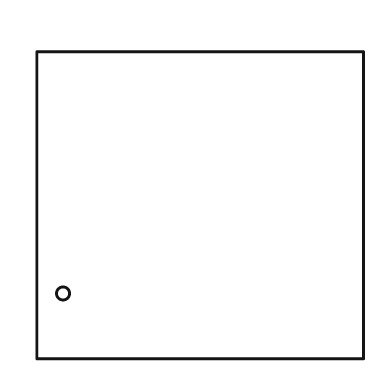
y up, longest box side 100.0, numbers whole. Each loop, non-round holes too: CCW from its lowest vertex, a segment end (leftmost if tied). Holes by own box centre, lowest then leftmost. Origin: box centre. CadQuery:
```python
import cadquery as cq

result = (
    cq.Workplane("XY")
    .moveTo(-50.0, -47.0)
    .lineTo(50.0, -47.0)
    .lineTo(50.0, 47.0)
    .lineTo(-50.0, 47.0)
    .close()
    .moveTo(-42.0, -27.0)
    .circle(2.0)
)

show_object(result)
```